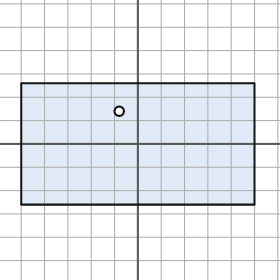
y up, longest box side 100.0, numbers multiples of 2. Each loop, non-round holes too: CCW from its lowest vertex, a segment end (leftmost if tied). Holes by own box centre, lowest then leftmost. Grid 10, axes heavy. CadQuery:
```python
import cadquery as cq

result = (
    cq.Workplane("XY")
    .moveTo(-50.0, -26.0)
    .lineTo(50.0, -26.0)
    .lineTo(50.0, 26.0)
    .lineTo(-50.0, 26.0)
    .close()
    .moveTo(-8.0, 14.0)
    .circle(2.0)
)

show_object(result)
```